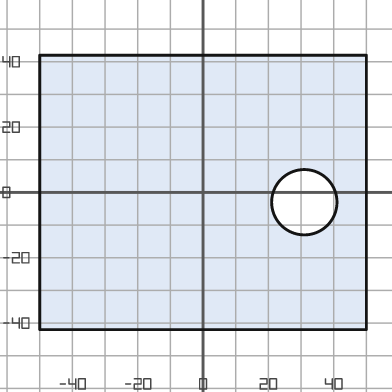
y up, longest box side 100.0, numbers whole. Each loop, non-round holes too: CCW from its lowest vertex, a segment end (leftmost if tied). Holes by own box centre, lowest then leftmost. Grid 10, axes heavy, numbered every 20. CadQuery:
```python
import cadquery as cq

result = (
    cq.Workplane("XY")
    .moveTo(-50.0, -42.0)
    .lineTo(50.0, -42.0)
    .lineTo(50.0, 42.0)
    .lineTo(-50.0, 42.0)
    .close()
    .moveTo(31.0, -3.0)
    .circle(10.0)
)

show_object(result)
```